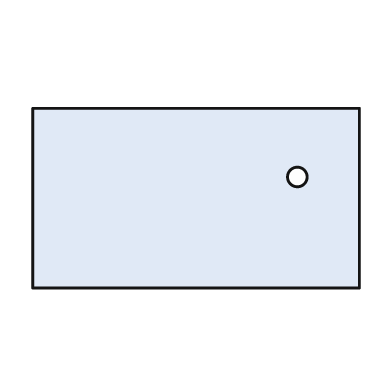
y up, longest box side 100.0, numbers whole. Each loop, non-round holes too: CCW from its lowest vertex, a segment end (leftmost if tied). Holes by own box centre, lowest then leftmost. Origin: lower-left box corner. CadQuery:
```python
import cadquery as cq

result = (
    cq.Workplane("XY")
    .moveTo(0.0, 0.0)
    .lineTo(100.0, 0.0)
    .lineTo(100.0, 55.0)
    .lineTo(0.0, 55.0)
    .close()
    .moveTo(81.0, 34.0)
    .circle(3.0)
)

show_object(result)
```